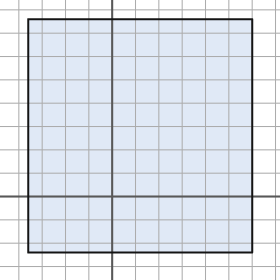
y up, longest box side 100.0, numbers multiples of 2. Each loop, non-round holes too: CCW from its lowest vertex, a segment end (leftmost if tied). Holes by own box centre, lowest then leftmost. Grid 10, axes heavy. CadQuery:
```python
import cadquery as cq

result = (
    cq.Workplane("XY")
    .moveTo(-36.0, -24.0)
    .lineTo(60.0, -24.0)
    .lineTo(60.0, 76.0)
    .lineTo(-36.0, 76.0)
    .close()
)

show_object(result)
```